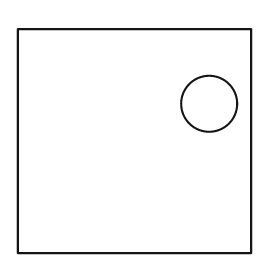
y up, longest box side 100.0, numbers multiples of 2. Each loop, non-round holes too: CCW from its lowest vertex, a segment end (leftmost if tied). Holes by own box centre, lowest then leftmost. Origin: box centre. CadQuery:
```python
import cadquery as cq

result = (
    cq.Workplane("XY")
    .moveTo(-50.0, -48.0)
    .lineTo(50.0, -48.0)
    .lineTo(50.0, 48.0)
    .lineTo(-50.0, 48.0)
    .close()
    .moveTo(32.0, 16.0)
    .circle(12.0)
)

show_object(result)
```